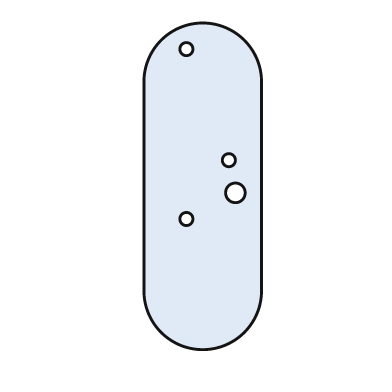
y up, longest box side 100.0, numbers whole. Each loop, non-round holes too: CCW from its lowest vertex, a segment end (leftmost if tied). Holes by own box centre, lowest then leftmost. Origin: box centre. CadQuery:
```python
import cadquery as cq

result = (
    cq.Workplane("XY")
    .moveTo(-18.0, -32.0)
    .threePointArc((0.0, -50.0), (18.0, -32.0))
    .lineTo(18.0, 32.0)
    .threePointArc((0.0, 50.0), (-18.0, 32.0))
    .close()
    .moveTo(-5.0, -10.0)
    .circle(2.0)
    .moveTo(10.0, -2.0)
    .circle(3.0)
    .moveTo(8.0, 8.0)
    .circle(2.0)
    .moveTo(-5.0, 42.0)
    .circle(2.0)
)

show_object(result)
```